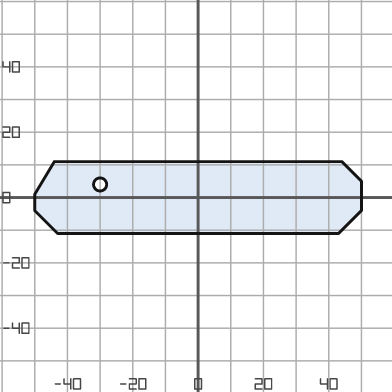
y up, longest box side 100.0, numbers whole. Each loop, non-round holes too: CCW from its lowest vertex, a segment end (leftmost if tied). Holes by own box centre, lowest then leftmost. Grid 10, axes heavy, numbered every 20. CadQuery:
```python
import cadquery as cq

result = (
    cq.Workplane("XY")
    .moveTo(-43.0, -11.0)
    .lineTo(43.0, -11.0)
    .lineTo(50.0, -4.0)
    .lineTo(50.0, 5.0)
    .lineTo(44.0, 11.0)
    .lineTo(-44.0, 11.0)
    .lineTo(-50.0, 1.0)
    .lineTo(-50.0, -4.0)
    .close()
    .moveTo(-30.0, 4.0)
    .circle(2.0)
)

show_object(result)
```